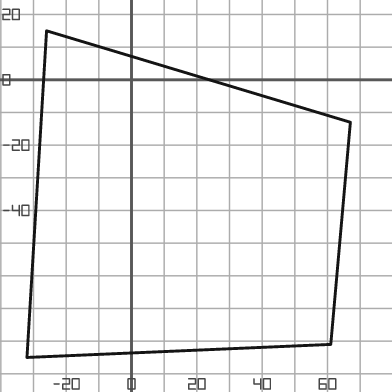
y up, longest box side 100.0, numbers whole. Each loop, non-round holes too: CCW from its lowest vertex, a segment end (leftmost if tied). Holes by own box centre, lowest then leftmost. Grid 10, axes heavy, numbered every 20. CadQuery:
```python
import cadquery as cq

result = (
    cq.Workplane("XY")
    .moveTo(-32.0, -85.0)
    .lineTo(61.0, -81.0)
    .lineTo(67.0, -13.0)
    .lineTo(-26.0, 15.0)
    .close()
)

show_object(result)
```